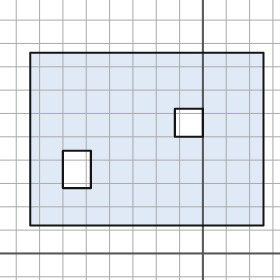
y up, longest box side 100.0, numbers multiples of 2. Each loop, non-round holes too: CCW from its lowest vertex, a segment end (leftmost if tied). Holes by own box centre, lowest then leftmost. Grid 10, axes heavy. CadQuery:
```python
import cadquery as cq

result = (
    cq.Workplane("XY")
    .moveTo(-74.0, 12.0)
    .lineTo(26.0, 12.0)
    .lineTo(26.0, 86.0)
    .lineTo(-74.0, 86.0)
    .close()
    .moveTo(-60.0, 28.0)
    .lineTo(-48.0, 28.0)
    .lineTo(-48.0, 44.0)
    .lineTo(-60.0, 44.0)
    .close()
    .moveTo(-12.0, 50.0)
    .lineTo(0.0, 50.0)
    .lineTo(0.0, 62.0)
    .lineTo(-12.0, 62.0)
    .close()
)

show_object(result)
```